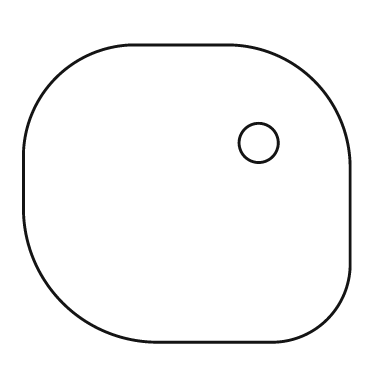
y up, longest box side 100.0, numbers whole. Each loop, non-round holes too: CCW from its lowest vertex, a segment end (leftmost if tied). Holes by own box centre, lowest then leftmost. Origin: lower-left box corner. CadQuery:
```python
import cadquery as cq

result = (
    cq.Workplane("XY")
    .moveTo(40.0, 0.0)
    .lineTo(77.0, 0.0)
    .threePointArc((93.0, 7.0), (100.0, 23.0))
    .lineTo(100.0, 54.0)
    .threePointArc((89.0, 80.0), (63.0, 91.0))
    .lineTo(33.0, 91.0)
    .threePointArc((10.0, 81.0), (0.0, 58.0))
    .lineTo(0.0, 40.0)
    .threePointArc((12.0, 12.0), (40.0, 0.0))
    .close()
    .moveTo(72.0, 61.0)
    .circle(6.0)
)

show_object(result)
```